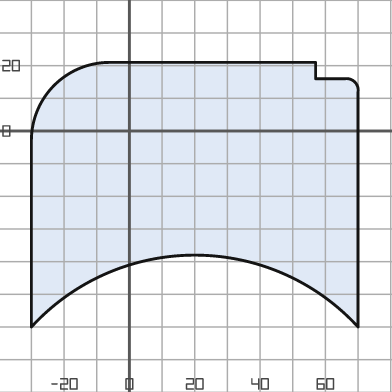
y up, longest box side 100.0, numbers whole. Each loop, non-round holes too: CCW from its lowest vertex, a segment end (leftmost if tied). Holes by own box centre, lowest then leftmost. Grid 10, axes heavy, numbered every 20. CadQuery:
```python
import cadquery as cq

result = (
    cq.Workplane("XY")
    .moveTo(-30.0, -60.0)
    .threePointArc((20.0, -38.0), (70.0, -60.0))
    .lineTo(70.0, 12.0)
    .threePointArc((69.0, 15.0), (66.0, 16.0))
    .lineTo(57.0, 16.0)
    .lineTo(57.0, 21.0)
    .lineTo(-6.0, 21.0)
    .threePointArc((-23.0, 14.0), (-30.0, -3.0))
    .close()
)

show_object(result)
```